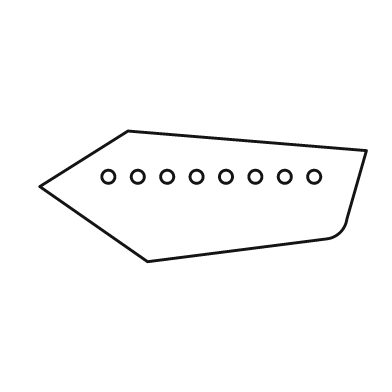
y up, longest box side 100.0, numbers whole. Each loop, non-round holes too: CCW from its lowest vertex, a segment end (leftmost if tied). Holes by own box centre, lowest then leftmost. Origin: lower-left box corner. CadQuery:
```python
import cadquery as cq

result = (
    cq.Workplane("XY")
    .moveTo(33.0, 0.0)
    .lineTo(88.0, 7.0)
    .threePointArc((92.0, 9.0), (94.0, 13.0))
    .lineTo(100.0, 34.0)
    .lineTo(27.0, 40.0)
    .lineTo(0.0, 23.0)
    .close()
    .moveTo(21.0, 26.0)
    .circle(2.0)
    .moveTo(30.0, 26.0)
    .circle(2.0)
    .moveTo(39.0, 26.0)
    .circle(2.0)
    .moveTo(48.0, 26.0)
    .circle(2.0)
    .moveTo(57.0, 26.0)
    .circle(2.0)
    .moveTo(66.0, 26.0)
    .circle(2.0)
    .moveTo(75.0, 26.0)
    .circle(2.0)
    .moveTo(84.0, 26.0)
    .circle(2.0)
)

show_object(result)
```